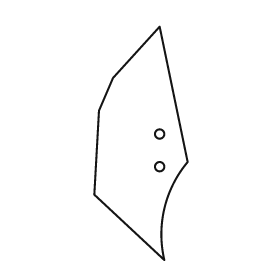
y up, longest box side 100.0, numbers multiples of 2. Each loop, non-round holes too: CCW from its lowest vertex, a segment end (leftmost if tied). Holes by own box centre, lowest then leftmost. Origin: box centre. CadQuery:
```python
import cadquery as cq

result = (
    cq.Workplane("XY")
    .moveTo(10.0, -50.0)
    .threePointArc((10.0, -28.0), (20.0, -8.0))
    .lineTo(8.0, 50.0)
    .lineTo(-12.0, 28.0)
    .lineTo(-18.0, 14.0)
    .lineTo(-20.0, -22.0)
    .close()
    .moveTo(8.0, -10.0)
    .circle(2.0)
    .moveTo(8.0, 4.0)
    .circle(2.0)
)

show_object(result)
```